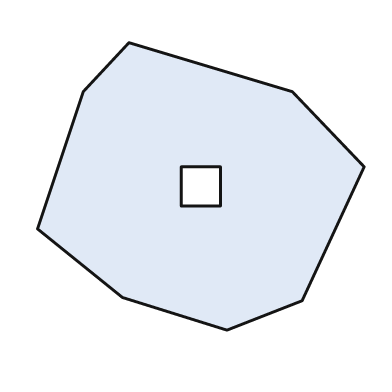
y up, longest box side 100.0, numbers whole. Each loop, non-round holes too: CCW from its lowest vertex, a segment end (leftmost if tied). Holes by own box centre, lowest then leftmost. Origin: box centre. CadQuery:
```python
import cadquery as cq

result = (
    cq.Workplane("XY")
    .moveTo(8.0, -44.0)
    .lineTo(31.0, -35.0)
    .lineTo(50.0, 6.0)
    .lineTo(28.0, 29.0)
    .lineTo(-22.0, 44.0)
    .lineTo(-36.0, 29.0)
    .lineTo(-50.0, -13.0)
    .lineTo(-24.0, -34.0)
    .close()
    .moveTo(-6.0, -6.0)
    .lineTo(6.0, -6.0)
    .lineTo(6.0, 6.0)
    .lineTo(-6.0, 6.0)
    .close()
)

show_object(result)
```